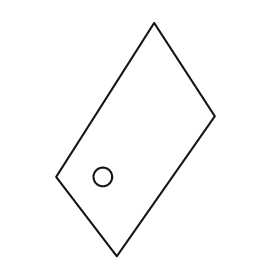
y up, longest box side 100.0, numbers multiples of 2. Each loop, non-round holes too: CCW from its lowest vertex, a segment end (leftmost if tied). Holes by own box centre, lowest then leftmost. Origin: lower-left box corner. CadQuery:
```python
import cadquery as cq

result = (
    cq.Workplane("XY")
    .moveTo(26.0, 0.0)
    .lineTo(68.0, 60.0)
    .lineTo(42.0, 100.0)
    .lineTo(0.0, 34.0)
    .close()
    .moveTo(20.0, 34.0)
    .circle(4.0)
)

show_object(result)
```